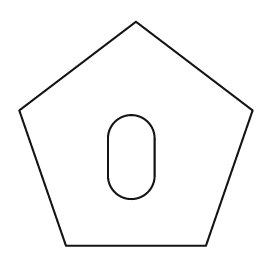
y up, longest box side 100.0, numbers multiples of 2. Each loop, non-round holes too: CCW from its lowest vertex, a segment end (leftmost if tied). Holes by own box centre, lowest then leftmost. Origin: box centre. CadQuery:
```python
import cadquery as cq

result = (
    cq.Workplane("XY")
    .moveTo(-30.0, -48.0)
    .lineTo(30.0, -48.0)
    .lineTo(50.0, 10.0)
    .lineTo(0.0, 48.0)
    .lineTo(-50.0, 10.0)
    .close()
    .moveTo(-12.0, -18.0)
    .threePointArc((-2.0, -28.0), (8.0, -18.0))
    .lineTo(8.0, -2.0)
    .threePointArc((-2.0, 8.0), (-12.0, -2.0))
    .close()
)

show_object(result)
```